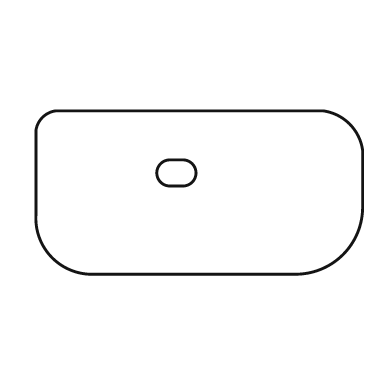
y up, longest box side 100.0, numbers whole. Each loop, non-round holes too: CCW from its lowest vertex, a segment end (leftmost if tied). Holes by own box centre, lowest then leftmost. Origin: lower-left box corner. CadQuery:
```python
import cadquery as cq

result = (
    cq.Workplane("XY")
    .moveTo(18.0, 0.0)
    .lineTo(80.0, 0.0)
    .threePointArc((94.0, 6.0), (100.0, 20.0))
    .lineTo(100.0, 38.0)
    .threePointArc((96.0, 46.0), (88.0, 50.0))
    .lineTo(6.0, 50.0)
    .threePointArc((2.0, 48.0), (0.0, 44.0))
    .lineTo(0.0, 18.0)
    .threePointArc((5.0, 5.0), (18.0, 0.0))
    .close()
    .moveTo(41.0, 27.0)
    .lineTo(45.0, 27.0)
    .threePointArc((49.0, 31.0), (45.0, 35.0))
    .lineTo(41.0, 35.0)
    .threePointArc((37.0, 31.0), (41.0, 27.0))
    .close()
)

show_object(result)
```